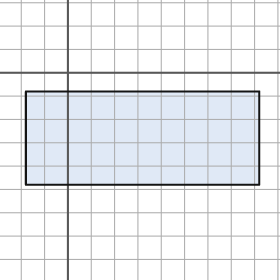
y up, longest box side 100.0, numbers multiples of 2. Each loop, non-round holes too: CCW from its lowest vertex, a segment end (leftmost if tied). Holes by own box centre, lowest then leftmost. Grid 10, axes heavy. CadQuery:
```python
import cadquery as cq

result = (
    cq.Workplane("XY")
    .moveTo(-18.0, -48.0)
    .lineTo(82.0, -48.0)
    .lineTo(82.0, -8.0)
    .lineTo(-18.0, -8.0)
    .close()
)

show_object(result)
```